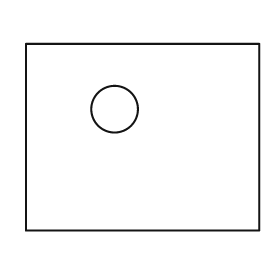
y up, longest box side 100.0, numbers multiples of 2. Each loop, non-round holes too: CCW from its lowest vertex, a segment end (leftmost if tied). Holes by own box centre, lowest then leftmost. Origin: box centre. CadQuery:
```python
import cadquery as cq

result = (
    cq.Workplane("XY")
    .moveTo(-50.0, -40.0)
    .lineTo(50.0, -40.0)
    .lineTo(50.0, 40.0)
    .lineTo(-50.0, 40.0)
    .close()
    .moveTo(-12.0, 12.0)
    .circle(10.0)
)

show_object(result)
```